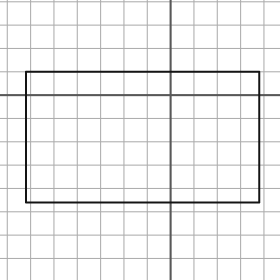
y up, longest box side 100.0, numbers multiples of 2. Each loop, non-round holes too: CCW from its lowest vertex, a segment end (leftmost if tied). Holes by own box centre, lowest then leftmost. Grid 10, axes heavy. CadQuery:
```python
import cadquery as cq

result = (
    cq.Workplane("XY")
    .moveTo(-62.0, -46.0)
    .lineTo(38.0, -46.0)
    .lineTo(38.0, 10.0)
    .lineTo(-62.0, 10.0)
    .close()
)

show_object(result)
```